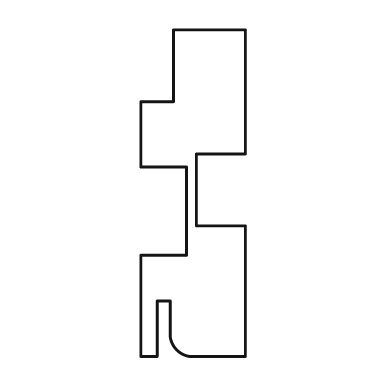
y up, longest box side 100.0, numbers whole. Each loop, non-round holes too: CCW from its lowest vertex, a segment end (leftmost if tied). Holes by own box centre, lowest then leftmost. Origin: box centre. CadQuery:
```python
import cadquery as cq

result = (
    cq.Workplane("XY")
    .moveTo(-16.0, -50.0)
    .lineTo(-11.0, -50.0)
    .lineTo(-11.0, -33.0)
    .lineTo(-7.0, -33.0)
    .lineTo(-7.0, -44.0)
    .threePointArc((-5.0, -48.0), (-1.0, -50.0))
    .lineTo(16.0, -50.0)
    .lineTo(16.0, -10.0)
    .lineTo(1.0, -10.0)
    .lineTo(1.0, 12.0)
    .lineTo(16.0, 12.0)
    .lineTo(16.0, 50.0)
    .lineTo(-6.0, 50.0)
    .lineTo(-6.0, 28.0)
    .lineTo(-16.0, 28.0)
    .lineTo(-16.0, 8.0)
    .lineTo(-2.0, 8.0)
    .lineTo(-2.0, -19.0)
    .lineTo(-16.0, -19.0)
    .close()
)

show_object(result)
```